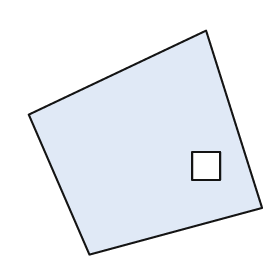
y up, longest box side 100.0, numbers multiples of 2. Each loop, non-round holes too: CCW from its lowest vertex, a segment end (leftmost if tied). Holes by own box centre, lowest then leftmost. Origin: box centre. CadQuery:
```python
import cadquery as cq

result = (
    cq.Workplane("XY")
    .moveTo(-24.0, -48.0)
    .lineTo(50.0, -28.0)
    .lineTo(26.0, 48.0)
    .lineTo(-50.0, 12.0)
    .close()
    .moveTo(20.0, -16.0)
    .lineTo(32.0, -16.0)
    .lineTo(32.0, -4.0)
    .lineTo(20.0, -4.0)
    .close()
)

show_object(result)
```